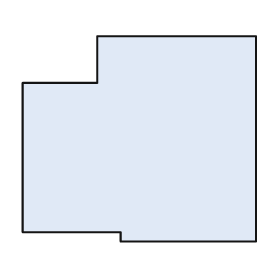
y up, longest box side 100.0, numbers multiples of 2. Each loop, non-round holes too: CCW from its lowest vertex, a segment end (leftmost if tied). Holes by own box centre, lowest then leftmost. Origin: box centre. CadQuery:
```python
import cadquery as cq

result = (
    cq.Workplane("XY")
    .moveTo(-8.0, -44.0)
    .lineTo(50.0, -44.0)
    .lineTo(50.0, 44.0)
    .lineTo(-18.0, 44.0)
    .lineTo(-18.0, 24.0)
    .lineTo(-50.0, 24.0)
    .lineTo(-50.0, -40.0)
    .lineTo(-8.0, -40.0)
    .close()
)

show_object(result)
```